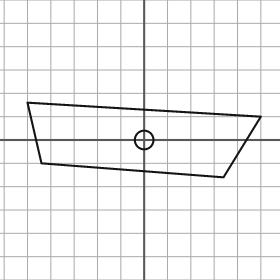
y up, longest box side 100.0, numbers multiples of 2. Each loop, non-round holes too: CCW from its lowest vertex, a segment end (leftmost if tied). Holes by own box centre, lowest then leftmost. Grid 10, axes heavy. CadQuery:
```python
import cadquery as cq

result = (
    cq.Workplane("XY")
    .moveTo(34.0, -16.0)
    .lineTo(50.0, 10.0)
    .lineTo(-50.0, 16.0)
    .lineTo(-44.0, -10.0)
    .close()
    .moveTo(0.0, 0.0)
    .circle(4.0)
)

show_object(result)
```